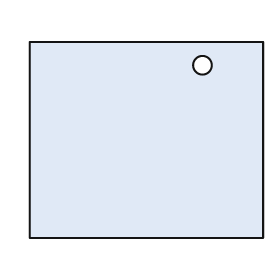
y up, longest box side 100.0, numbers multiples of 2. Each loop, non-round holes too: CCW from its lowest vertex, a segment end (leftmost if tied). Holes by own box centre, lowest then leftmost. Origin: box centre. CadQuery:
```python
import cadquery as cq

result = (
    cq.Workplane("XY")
    .moveTo(-50.0, -42.0)
    .lineTo(50.0, -42.0)
    .lineTo(50.0, 42.0)
    .lineTo(-50.0, 42.0)
    .close()
    .moveTo(24.0, 32.0)
    .circle(4.0)
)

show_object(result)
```